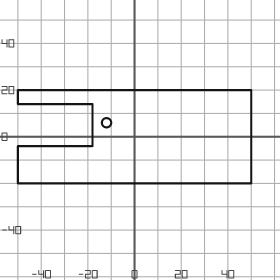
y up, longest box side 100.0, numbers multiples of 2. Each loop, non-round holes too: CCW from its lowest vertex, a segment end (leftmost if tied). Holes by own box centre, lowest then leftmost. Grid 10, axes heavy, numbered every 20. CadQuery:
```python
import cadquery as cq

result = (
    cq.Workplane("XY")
    .moveTo(-50.0, -20.0)
    .lineTo(50.0, -20.0)
    .lineTo(50.0, 20.0)
    .lineTo(-50.0, 20.0)
    .lineTo(-50.0, 14.0)
    .lineTo(-18.0, 14.0)
    .lineTo(-18.0, -4.0)
    .lineTo(-50.0, -4.0)
    .close()
    .moveTo(-12.0, 6.0)
    .circle(2.0)
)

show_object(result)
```